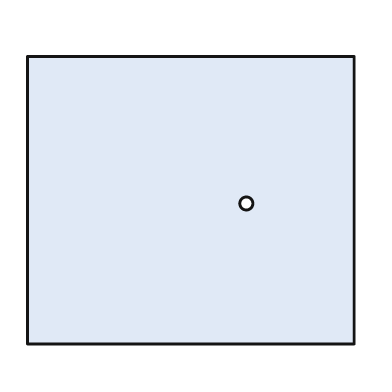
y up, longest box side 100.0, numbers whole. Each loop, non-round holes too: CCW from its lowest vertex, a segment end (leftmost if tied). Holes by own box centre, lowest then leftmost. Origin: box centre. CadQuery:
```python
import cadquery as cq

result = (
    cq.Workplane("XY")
    .moveTo(-50.0, -44.0)
    .lineTo(50.0, -44.0)
    .lineTo(50.0, 44.0)
    .lineTo(-50.0, 44.0)
    .close()
    .moveTo(17.0, -1.0)
    .circle(2.0)
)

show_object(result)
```